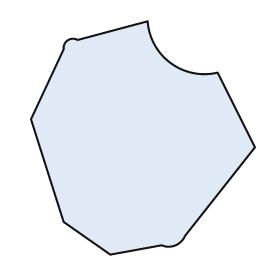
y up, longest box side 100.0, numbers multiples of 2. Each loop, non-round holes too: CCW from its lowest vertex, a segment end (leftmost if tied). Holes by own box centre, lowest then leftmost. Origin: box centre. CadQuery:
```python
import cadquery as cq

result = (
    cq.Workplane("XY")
    .moveTo(-14.0, -50.0)
    .lineTo(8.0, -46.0)
    .threePointArc((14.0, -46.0), (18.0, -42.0))
    .lineTo(48.0, -4.0)
    .lineTo(32.0, 28.0)
    .threePointArc((12.0, 32.0), (2.0, 50.0))
    .lineTo(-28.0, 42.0)
    .threePointArc((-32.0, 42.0), (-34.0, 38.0))
    .lineTo(-48.0, 8.0)
    .lineTo(-34.0, -36.0)
    .close()
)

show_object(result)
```